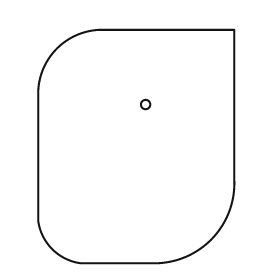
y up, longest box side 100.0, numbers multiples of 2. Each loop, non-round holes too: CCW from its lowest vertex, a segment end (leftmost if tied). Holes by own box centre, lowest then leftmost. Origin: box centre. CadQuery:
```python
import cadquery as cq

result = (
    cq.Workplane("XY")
    .moveTo(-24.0, -50.0)
    .lineTo(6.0, -50.0)
    .threePointArc((32.0, -40.0), (42.0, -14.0))
    .lineTo(42.0, 50.0)
    .lineTo(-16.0, 50.0)
    .threePointArc((-34.0, 42.0), (-42.0, 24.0))
    .lineTo(-42.0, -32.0)
    .threePointArc((-36.0, -44.0), (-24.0, -50.0))
    .close()
    .moveTo(4.0, 18.0)
    .circle(2.0)
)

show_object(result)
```